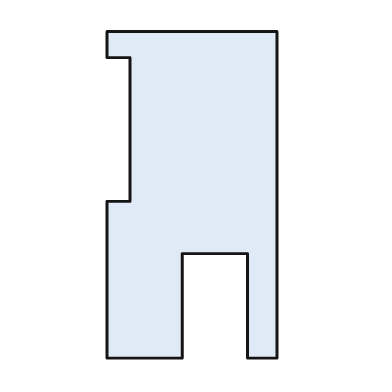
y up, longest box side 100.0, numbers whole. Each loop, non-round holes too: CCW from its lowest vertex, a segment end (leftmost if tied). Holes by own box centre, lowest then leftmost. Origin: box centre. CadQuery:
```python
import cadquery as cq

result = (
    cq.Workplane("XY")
    .moveTo(-26.0, -50.0)
    .lineTo(-3.0, -50.0)
    .lineTo(-3.0, -18.0)
    .lineTo(17.0, -18.0)
    .lineTo(17.0, -50.0)
    .lineTo(26.0, -50.0)
    .lineTo(26.0, 50.0)
    .lineTo(-26.0, 50.0)
    .lineTo(-26.0, 42.0)
    .lineTo(-19.0, 42.0)
    .lineTo(-19.0, -2.0)
    .lineTo(-26.0, -2.0)
    .close()
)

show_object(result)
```